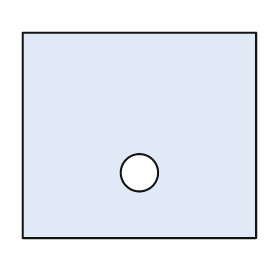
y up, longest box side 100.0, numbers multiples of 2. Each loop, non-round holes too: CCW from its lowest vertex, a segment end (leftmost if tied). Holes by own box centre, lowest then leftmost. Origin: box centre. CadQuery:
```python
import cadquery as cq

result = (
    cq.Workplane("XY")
    .moveTo(-50.0, -44.0)
    .lineTo(50.0, -44.0)
    .lineTo(50.0, 44.0)
    .lineTo(-50.0, 44.0)
    .close()
    .moveTo(0.0, -16.0)
    .circle(8.0)
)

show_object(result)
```